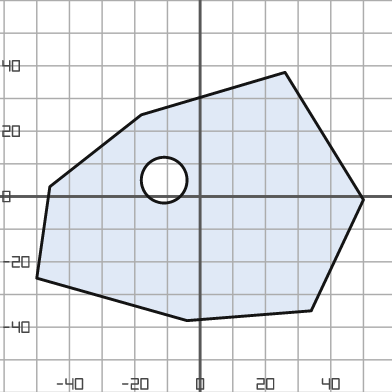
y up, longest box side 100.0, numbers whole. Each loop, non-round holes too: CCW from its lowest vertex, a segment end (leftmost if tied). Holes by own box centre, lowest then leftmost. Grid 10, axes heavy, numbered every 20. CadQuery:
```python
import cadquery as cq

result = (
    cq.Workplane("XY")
    .moveTo(-4.0, -38.0)
    .lineTo(34.0, -35.0)
    .lineTo(50.0, -1.0)
    .lineTo(26.0, 38.0)
    .lineTo(-18.0, 25.0)
    .lineTo(-46.0, 3.0)
    .lineTo(-50.0, -25.0)
    .close()
    .moveTo(-11.0, 5.0)
    .circle(7.0)
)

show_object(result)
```